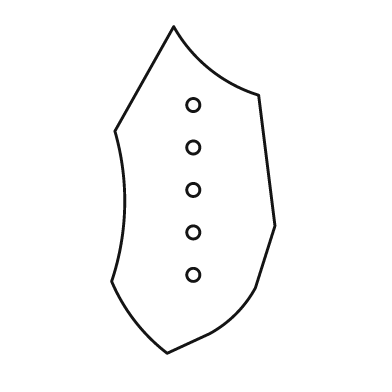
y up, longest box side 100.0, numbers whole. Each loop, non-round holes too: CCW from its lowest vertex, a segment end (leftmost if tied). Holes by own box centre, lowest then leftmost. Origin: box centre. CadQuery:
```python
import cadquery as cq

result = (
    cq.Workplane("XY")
    .moveTo(-8.0, -50.0)
    .lineTo(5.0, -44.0)
    .threePointArc((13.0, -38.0), (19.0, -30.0))
    .lineTo(25.0, -11.0)
    .lineTo(20.0, 29.0)
    .threePointArc((5.0, 37.0), (-6.0, 50.0))
    .lineTo(-24.0, 18.0)
    .threePointArc((-21.0, -5.0), (-25.0, -28.0))
    .threePointArc((-18.0, -40.0), (-8.0, -50.0))
    .close()
    .moveTo(0.0, -26.0)
    .circle(2.0)
    .moveTo(0.0, -13.0)
    .circle(2.0)
    .moveTo(0.0, 0.0)
    .circle(2.0)
    .moveTo(0.0, 13.0)
    .circle(2.0)
    .moveTo(0.0, 26.0)
    .circle(2.0)
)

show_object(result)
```